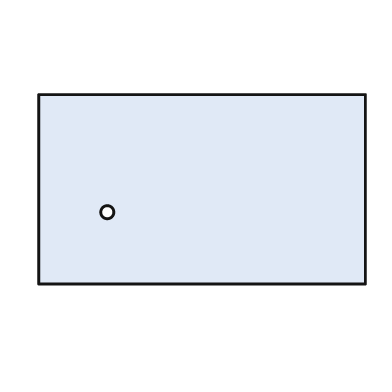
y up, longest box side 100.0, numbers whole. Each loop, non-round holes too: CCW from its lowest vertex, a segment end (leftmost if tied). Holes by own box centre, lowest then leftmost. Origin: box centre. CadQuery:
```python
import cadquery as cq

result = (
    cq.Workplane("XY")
    .moveTo(-50.0, -29.0)
    .lineTo(50.0, -29.0)
    .lineTo(50.0, 29.0)
    .lineTo(-50.0, 29.0)
    .close()
    .moveTo(-29.0, -7.0)
    .circle(2.0)
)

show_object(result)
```